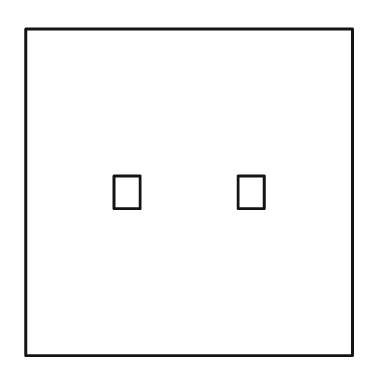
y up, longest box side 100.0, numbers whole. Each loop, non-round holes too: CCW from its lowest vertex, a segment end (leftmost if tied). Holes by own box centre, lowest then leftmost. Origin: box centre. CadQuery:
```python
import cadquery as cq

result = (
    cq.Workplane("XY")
    .moveTo(-50.0, -50.0)
    .lineTo(50.0, -50.0)
    .lineTo(50.0, 50.0)
    .lineTo(-50.0, 50.0)
    .close()
    .moveTo(-23.0, -5.0)
    .lineTo(-15.0, -5.0)
    .lineTo(-15.0, 5.0)
    .lineTo(-23.0, 5.0)
    .close()
    .moveTo(15.0, -5.0)
    .lineTo(23.0, -5.0)
    .lineTo(23.0, 5.0)
    .lineTo(15.0, 5.0)
    .close()
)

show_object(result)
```